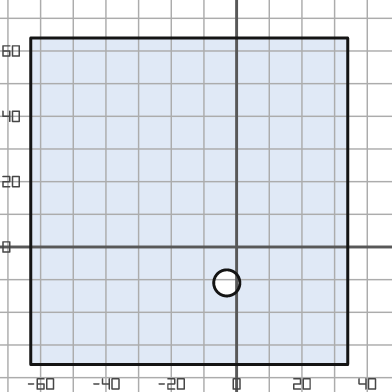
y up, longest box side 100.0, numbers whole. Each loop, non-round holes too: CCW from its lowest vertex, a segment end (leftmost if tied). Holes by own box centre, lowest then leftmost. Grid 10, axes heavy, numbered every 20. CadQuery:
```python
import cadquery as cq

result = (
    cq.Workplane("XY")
    .moveTo(-63.0, -36.0)
    .lineTo(34.0, -36.0)
    .lineTo(34.0, 64.0)
    .lineTo(-63.0, 64.0)
    .close()
    .moveTo(-3.0, -11.0)
    .circle(4.0)
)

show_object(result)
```